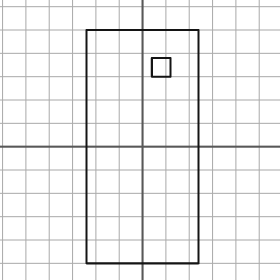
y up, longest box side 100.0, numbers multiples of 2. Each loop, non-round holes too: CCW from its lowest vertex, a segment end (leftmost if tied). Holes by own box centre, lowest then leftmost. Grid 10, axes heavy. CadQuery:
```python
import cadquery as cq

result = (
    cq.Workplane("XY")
    .moveTo(-24.0, -50.0)
    .lineTo(24.0, -50.0)
    .lineTo(24.0, 50.0)
    .lineTo(-24.0, 50.0)
    .close()
    .moveTo(4.0, 30.0)
    .lineTo(12.0, 30.0)
    .lineTo(12.0, 38.0)
    .lineTo(4.0, 38.0)
    .close()
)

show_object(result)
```